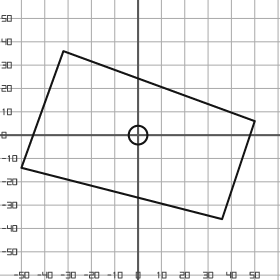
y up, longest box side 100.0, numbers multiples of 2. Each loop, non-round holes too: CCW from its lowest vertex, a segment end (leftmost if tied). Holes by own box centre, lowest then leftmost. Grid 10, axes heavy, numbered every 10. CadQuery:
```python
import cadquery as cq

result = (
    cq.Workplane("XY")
    .moveTo(36.0, -36.0)
    .lineTo(50.0, 6.0)
    .lineTo(-32.0, 36.0)
    .lineTo(-50.0, -14.0)
    .close()
    .moveTo(0.0, 0.0)
    .circle(4.0)
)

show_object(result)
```